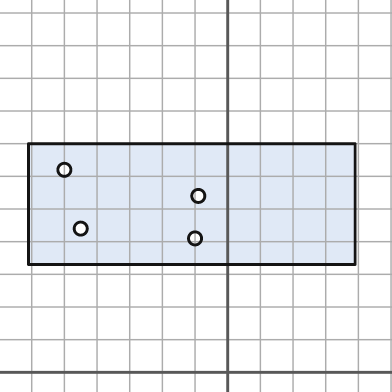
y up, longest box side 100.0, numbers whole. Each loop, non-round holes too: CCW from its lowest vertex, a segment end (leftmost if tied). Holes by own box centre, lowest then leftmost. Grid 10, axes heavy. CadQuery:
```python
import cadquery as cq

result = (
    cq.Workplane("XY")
    .moveTo(-61.0, 33.0)
    .lineTo(39.0, 33.0)
    .lineTo(39.0, 70.0)
    .lineTo(-61.0, 70.0)
    .close()
    .moveTo(-10.0, 41.0)
    .circle(2.0)
    .moveTo(-45.0, 44.0)
    .circle(2.0)
    .moveTo(-9.0, 54.0)
    .circle(2.0)
    .moveTo(-50.0, 62.0)
    .circle(2.0)
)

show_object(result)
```